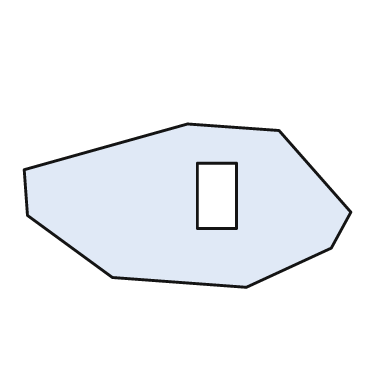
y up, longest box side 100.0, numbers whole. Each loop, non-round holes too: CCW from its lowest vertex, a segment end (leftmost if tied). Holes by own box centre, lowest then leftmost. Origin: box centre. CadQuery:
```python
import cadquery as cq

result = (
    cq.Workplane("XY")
    .moveTo(18.0, -25.0)
    .lineTo(44.0, -13.0)
    .lineTo(50.0, -2.0)
    .lineTo(28.0, 23.0)
    .lineTo(0.0, 25.0)
    .lineTo(-50.0, 11.0)
    .lineTo(-49.0, -3.0)
    .lineTo(-23.0, -22.0)
    .close()
    .moveTo(3.0, -7.0)
    .lineTo(15.0, -7.0)
    .lineTo(15.0, 13.0)
    .lineTo(3.0, 13.0)
    .close()
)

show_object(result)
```